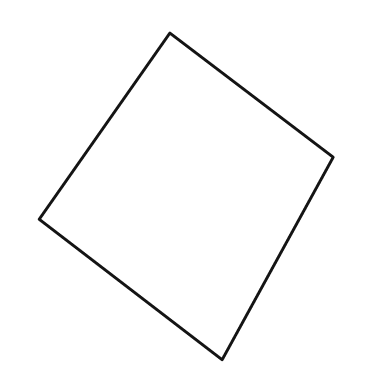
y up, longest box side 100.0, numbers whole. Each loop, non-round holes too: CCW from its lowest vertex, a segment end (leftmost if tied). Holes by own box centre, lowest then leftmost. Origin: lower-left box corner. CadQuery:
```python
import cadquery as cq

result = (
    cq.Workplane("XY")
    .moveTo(56.0, 0.0)
    .lineTo(90.0, 62.0)
    .lineTo(40.0, 100.0)
    .lineTo(0.0, 43.0)
    .close()
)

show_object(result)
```